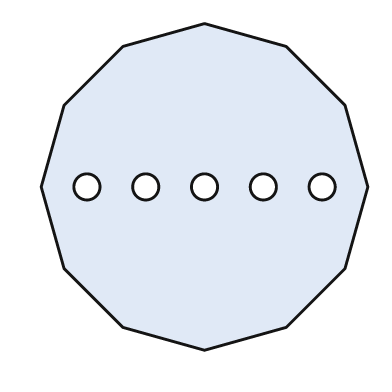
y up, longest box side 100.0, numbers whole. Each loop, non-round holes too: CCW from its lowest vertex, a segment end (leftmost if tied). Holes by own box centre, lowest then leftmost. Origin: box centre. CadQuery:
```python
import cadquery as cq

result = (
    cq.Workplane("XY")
    .moveTo(0.0, -50.0)
    .lineTo(25.0, -43.0)
    .lineTo(43.0, -25.0)
    .lineTo(50.0, 0.0)
    .lineTo(43.0, 25.0)
    .lineTo(25.0, 43.0)
    .lineTo(0.0, 50.0)
    .lineTo(-25.0, 43.0)
    .lineTo(-43.0, 25.0)
    .lineTo(-50.0, 0.0)
    .lineTo(-43.0, -25.0)
    .lineTo(-25.0, -43.0)
    .close()
    .moveTo(-36.0, 0.0)
    .circle(4.0)
    .moveTo(-18.0, 0.0)
    .circle(4.0)
    .moveTo(0.0, 0.0)
    .circle(4.0)
    .moveTo(18.0, 0.0)
    .circle(4.0)
    .moveTo(36.0, 0.0)
    .circle(4.0)
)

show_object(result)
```